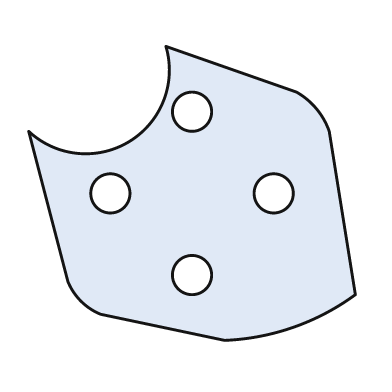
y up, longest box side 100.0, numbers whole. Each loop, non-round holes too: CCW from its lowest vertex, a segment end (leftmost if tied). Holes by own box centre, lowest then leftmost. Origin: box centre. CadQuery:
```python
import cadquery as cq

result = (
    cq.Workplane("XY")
    .moveTo(10.0, -45.0)
    .threePointArc((31.0, -41.0), (50.0, -31.0))
    .lineTo(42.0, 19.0)
    .threePointArc((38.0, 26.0), (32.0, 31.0))
    .lineTo(-8.0, 45.0)
    .threePointArc((-19.0, 16.0), (-50.0, 19.0))
    .lineTo(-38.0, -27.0)
    .threePointArc((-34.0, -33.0), (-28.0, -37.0))
    .close()
    .moveTo(0.0, -25.0)
    .circle(6.0)
    .moveTo(-25.0, 0.0)
    .circle(6.0)
    .moveTo(25.0, 0.0)
    .circle(6.0)
    .moveTo(0.0, 25.0)
    .circle(6.0)
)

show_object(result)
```